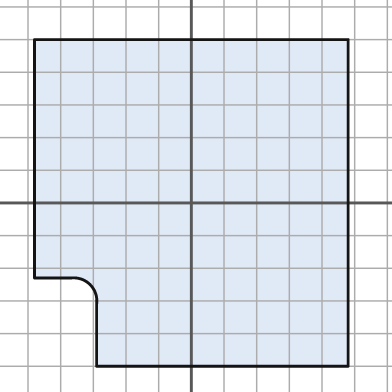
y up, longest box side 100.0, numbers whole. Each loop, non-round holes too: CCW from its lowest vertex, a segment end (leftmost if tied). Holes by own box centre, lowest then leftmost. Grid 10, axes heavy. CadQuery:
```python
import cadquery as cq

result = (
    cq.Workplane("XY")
    .moveTo(-29.0, -50.0)
    .lineTo(48.0, -50.0)
    .lineTo(48.0, 50.0)
    .lineTo(-48.0, 50.0)
    .lineTo(-48.0, -23.0)
    .lineTo(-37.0, -23.0)
    .threePointArc((-31.0, -25.0), (-29.0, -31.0))
    .close()
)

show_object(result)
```